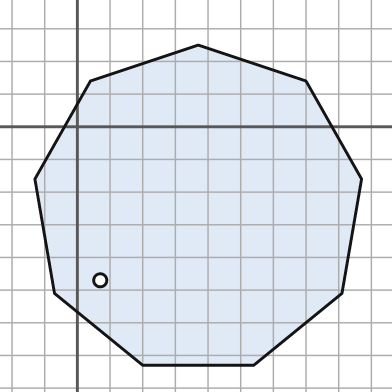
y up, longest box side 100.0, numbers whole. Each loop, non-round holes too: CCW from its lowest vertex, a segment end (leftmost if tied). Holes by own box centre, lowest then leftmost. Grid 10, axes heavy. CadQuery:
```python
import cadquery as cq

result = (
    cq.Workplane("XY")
    .moveTo(20.0, -73.0)
    .lineTo(54.0, -73.0)
    .lineTo(81.0, -51.0)
    .lineTo(87.0, -16.0)
    .lineTo(70.0, 14.0)
    .lineTo(37.0, 25.0)
    .lineTo(4.0, 14.0)
    .lineTo(-13.0, -16.0)
    .lineTo(-7.0, -51.0)
    .close()
    .moveTo(7.0, -47.0)
    .circle(2.0)
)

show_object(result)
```